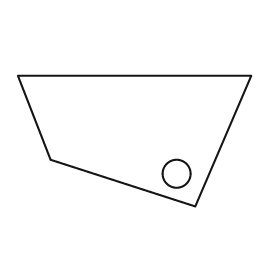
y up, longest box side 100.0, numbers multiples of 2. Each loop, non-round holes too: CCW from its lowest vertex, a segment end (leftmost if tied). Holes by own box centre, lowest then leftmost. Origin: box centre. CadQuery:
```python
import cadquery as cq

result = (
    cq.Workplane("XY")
    .moveTo(26.0, -28.0)
    .lineTo(50.0, 28.0)
    .lineTo(-50.0, 28.0)
    .lineTo(-36.0, -8.0)
    .close()
    .moveTo(18.0, -14.0)
    .circle(6.0)
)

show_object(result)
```